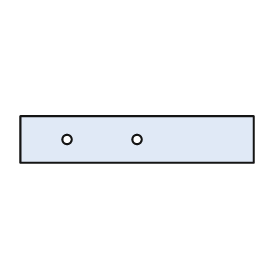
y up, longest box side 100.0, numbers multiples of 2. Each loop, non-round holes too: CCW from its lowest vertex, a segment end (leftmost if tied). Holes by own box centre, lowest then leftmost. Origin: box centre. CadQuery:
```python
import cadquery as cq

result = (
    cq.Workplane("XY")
    .moveTo(-50.0, -10.0)
    .lineTo(50.0, -10.0)
    .lineTo(50.0, 10.0)
    .lineTo(-50.0, 10.0)
    .close()
    .moveTo(-30.0, 0.0)
    .circle(2.0)
    .moveTo(0.0, 0.0)
    .circle(2.0)
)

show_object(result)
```